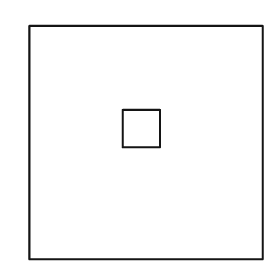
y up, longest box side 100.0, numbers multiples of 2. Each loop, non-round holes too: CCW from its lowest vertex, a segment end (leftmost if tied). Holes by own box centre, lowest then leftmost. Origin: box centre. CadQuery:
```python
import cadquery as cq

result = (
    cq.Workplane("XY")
    .moveTo(-50.0, -50.0)
    .lineTo(50.0, -50.0)
    .lineTo(50.0, 50.0)
    .lineTo(-50.0, 50.0)
    .close()
    .moveTo(-10.0, -2.0)
    .lineTo(6.0, -2.0)
    .lineTo(6.0, 14.0)
    .lineTo(-10.0, 14.0)
    .close()
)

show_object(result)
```